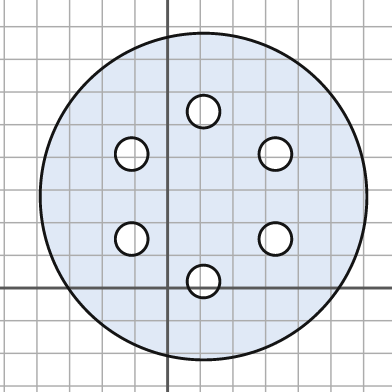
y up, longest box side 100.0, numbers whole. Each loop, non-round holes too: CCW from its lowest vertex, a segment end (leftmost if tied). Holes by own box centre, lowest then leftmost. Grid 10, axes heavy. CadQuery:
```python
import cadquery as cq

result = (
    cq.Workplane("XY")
    .moveTo(11.0, 28.0)
    .circle(50.0)
    .moveTo(11.0, 2.0)
    .circle(5.0)
    .moveTo(-11.0, 15.0)
    .circle(5.0)
    .moveTo(33.0, 15.0)
    .circle(5.0)
    .moveTo(-11.0, 41.0)
    .circle(5.0)
    .moveTo(33.0, 41.0)
    .circle(5.0)
    .moveTo(11.0, 54.0)
    .circle(5.0)
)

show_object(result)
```